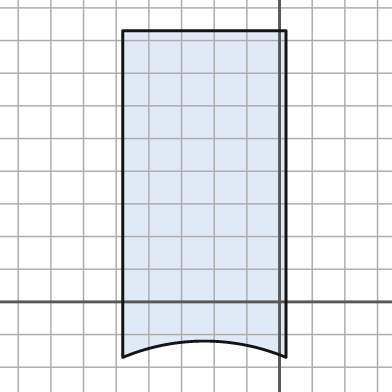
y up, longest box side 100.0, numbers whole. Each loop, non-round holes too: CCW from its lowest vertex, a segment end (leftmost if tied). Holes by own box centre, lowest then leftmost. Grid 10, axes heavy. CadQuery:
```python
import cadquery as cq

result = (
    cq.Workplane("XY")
    .moveTo(-48.0, -17.0)
    .threePointArc((-23.0, -12.0), (2.0, -17.0))
    .lineTo(2.0, 83.0)
    .lineTo(-48.0, 83.0)
    .close()
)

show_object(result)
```